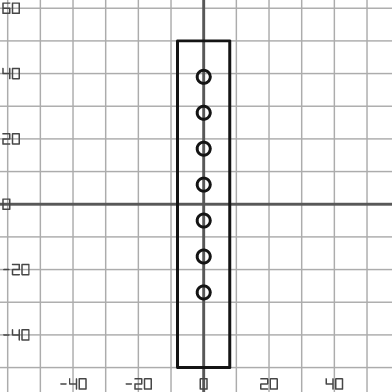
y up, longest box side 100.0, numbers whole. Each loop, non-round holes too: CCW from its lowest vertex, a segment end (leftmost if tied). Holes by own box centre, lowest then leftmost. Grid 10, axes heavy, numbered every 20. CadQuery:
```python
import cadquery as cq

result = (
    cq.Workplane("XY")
    .moveTo(-8.0, -50.0)
    .lineTo(8.0, -50.0)
    .lineTo(8.0, 50.0)
    .lineTo(-8.0, 50.0)
    .close()
    .moveTo(0.0, -27.0)
    .circle(2.0)
    .moveTo(0.0, -16.0)
    .circle(2.0)
    .moveTo(0.0, -5.0)
    .circle(2.0)
    .moveTo(0.0, 6.0)
    .circle(2.0)
    .moveTo(0.0, 17.0)
    .circle(2.0)
    .moveTo(0.0, 28.0)
    .circle(2.0)
    .moveTo(0.0, 39.0)
    .circle(2.0)
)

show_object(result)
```